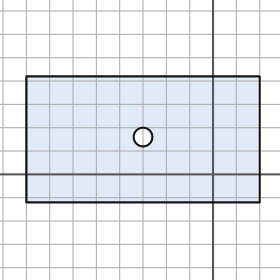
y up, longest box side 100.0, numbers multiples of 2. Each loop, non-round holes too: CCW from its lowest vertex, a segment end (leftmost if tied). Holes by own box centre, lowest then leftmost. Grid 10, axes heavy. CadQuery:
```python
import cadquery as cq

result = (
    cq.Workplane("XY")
    .moveTo(-80.0, -12.0)
    .lineTo(20.0, -12.0)
    .lineTo(20.0, 42.0)
    .lineTo(-80.0, 42.0)
    .close()
    .moveTo(-30.0, 16.0)
    .circle(4.0)
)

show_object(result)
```